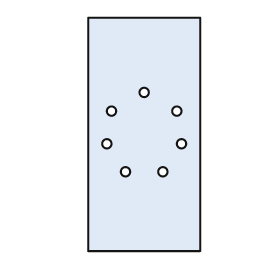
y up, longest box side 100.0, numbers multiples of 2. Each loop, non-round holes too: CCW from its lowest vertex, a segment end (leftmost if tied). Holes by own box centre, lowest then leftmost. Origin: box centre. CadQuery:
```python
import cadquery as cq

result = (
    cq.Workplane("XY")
    .moveTo(-24.0, -50.0)
    .lineTo(24.0, -50.0)
    .lineTo(24.0, 50.0)
    .lineTo(-24.0, 50.0)
    .close()
    .moveTo(-8.0, -16.0)
    .circle(2.0)
    .moveTo(8.0, -16.0)
    .circle(2.0)
    .moveTo(-16.0, -4.0)
    .circle(2.0)
    .moveTo(16.0, -4.0)
    .circle(2.0)
    .moveTo(-14.0, 10.0)
    .circle(2.0)
    .moveTo(14.0, 10.0)
    .circle(2.0)
    .moveTo(0.0, 18.0)
    .circle(2.0)
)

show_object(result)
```